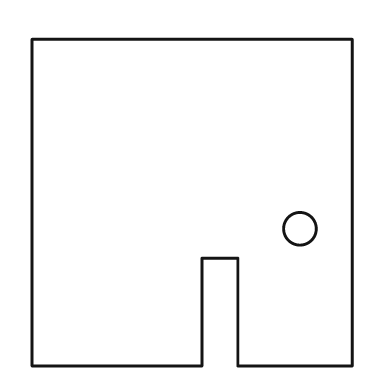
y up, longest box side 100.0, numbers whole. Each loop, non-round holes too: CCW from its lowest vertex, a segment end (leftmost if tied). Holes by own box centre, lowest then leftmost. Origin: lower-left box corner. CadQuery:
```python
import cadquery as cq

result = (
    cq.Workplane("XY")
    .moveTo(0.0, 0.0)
    .lineTo(52.0, 0.0)
    .lineTo(52.0, 33.0)
    .lineTo(63.0, 33.0)
    .lineTo(63.0, 0.0)
    .lineTo(98.0, 0.0)
    .lineTo(98.0, 100.0)
    .lineTo(0.0, 100.0)
    .close()
    .moveTo(82.0, 42.0)
    .circle(5.0)
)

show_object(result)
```